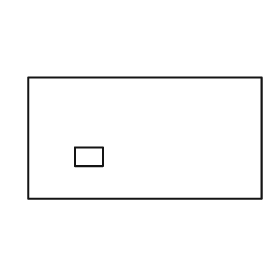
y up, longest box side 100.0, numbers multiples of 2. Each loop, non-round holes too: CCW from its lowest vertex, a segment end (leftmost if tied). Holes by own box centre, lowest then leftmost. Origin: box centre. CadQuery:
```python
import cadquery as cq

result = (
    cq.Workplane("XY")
    .moveTo(-50.0, -26.0)
    .lineTo(50.0, -26.0)
    .lineTo(50.0, 26.0)
    .lineTo(-50.0, 26.0)
    .close()
    .moveTo(-30.0, -12.0)
    .lineTo(-18.0, -12.0)
    .lineTo(-18.0, -4.0)
    .lineTo(-30.0, -4.0)
    .close()
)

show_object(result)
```